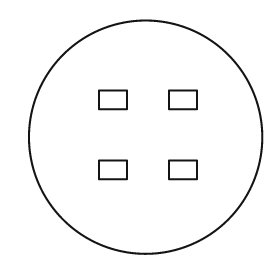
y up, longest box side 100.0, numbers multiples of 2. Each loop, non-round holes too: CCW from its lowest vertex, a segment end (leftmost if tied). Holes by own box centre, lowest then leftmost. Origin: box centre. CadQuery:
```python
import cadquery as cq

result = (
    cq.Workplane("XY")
    .moveTo(0.0, 0.0)
    .circle(50.0)
    .moveTo(-20.0, -18.0)
    .lineTo(-8.0, -18.0)
    .lineTo(-8.0, -10.0)
    .lineTo(-20.0, -10.0)
    .close()
    .moveTo(10.0, -18.0)
    .lineTo(22.0, -18.0)
    .lineTo(22.0, -10.0)
    .lineTo(10.0, -10.0)
    .close()
    .moveTo(-20.0, 12.0)
    .lineTo(-8.0, 12.0)
    .lineTo(-8.0, 20.0)
    .lineTo(-20.0, 20.0)
    .close()
    .moveTo(10.0, 12.0)
    .lineTo(22.0, 12.0)
    .lineTo(22.0, 20.0)
    .lineTo(10.0, 20.0)
    .close()
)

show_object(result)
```